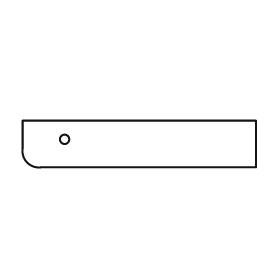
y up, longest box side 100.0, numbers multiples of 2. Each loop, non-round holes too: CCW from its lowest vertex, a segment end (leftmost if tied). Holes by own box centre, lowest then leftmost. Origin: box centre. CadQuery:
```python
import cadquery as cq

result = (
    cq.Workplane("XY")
    .moveTo(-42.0, -10.0)
    .lineTo(50.0, -10.0)
    .lineTo(50.0, 10.0)
    .lineTo(-50.0, 10.0)
    .lineTo(-50.0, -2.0)
    .threePointArc((-48.0, -8.0), (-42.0, -10.0))
    .close()
    .moveTo(-32.0, 2.0)
    .circle(2.0)
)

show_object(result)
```